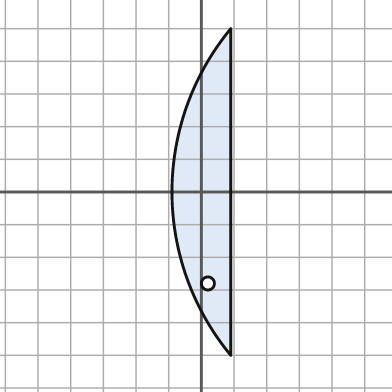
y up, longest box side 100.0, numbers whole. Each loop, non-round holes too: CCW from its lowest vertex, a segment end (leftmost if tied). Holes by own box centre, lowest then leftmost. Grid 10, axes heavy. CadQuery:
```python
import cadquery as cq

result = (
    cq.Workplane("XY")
    .moveTo(9.0, -50.0)
    .lineTo(9.0, 50.0)
    .threePointArc((-9.0, 0.0), (9.0, -50.0))
    .close()
    .moveTo(2.0, -28.0)
    .circle(2.0)
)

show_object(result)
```